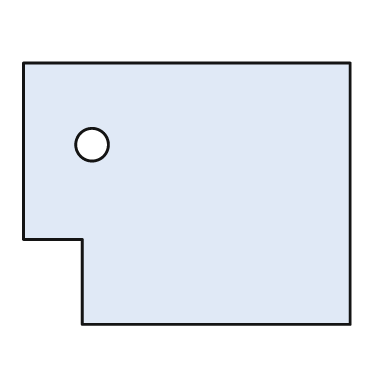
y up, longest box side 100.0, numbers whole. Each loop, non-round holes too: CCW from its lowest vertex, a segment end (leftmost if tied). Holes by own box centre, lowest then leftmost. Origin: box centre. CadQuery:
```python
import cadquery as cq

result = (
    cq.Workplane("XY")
    .moveTo(-32.0, -40.0)
    .lineTo(50.0, -40.0)
    .lineTo(50.0, 40.0)
    .lineTo(-50.0, 40.0)
    .lineTo(-50.0, -14.0)
    .lineTo(-32.0, -14.0)
    .close()
    .moveTo(-29.0, 15.0)
    .circle(5.0)
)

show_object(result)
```